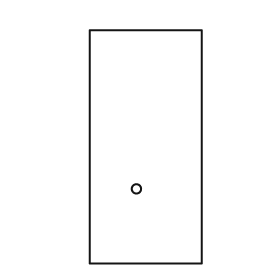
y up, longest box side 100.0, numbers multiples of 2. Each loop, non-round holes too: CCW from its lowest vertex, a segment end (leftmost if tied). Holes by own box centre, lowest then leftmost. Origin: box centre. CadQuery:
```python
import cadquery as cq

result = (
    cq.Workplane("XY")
    .moveTo(-24.0, -50.0)
    .lineTo(24.0, -50.0)
    .lineTo(24.0, 50.0)
    .lineTo(-24.0, 50.0)
    .close()
    .moveTo(-4.0, -18.0)
    .circle(2.0)
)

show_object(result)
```